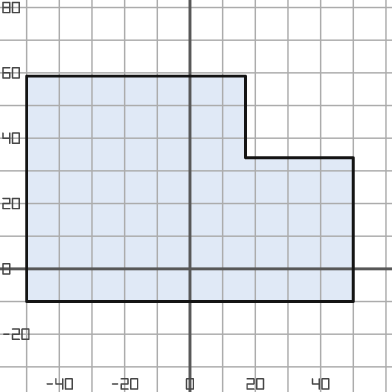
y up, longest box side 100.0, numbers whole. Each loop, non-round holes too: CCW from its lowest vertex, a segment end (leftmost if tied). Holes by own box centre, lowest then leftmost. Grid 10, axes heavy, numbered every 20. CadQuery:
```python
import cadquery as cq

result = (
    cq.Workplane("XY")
    .moveTo(-50.0, -10.0)
    .lineTo(50.0, -10.0)
    .lineTo(50.0, 34.0)
    .lineTo(17.0, 34.0)
    .lineTo(17.0, 59.0)
    .lineTo(-50.0, 59.0)
    .close()
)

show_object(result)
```